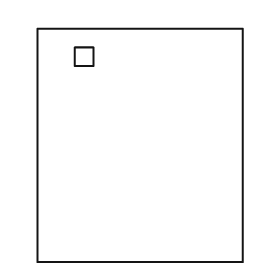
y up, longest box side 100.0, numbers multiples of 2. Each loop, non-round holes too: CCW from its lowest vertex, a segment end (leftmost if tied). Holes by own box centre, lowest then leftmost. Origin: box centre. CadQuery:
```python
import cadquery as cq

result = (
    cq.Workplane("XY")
    .moveTo(-44.0, -50.0)
    .lineTo(44.0, -50.0)
    .lineTo(44.0, 50.0)
    .lineTo(-44.0, 50.0)
    .close()
    .moveTo(-28.0, 34.0)
    .lineTo(-20.0, 34.0)
    .lineTo(-20.0, 42.0)
    .lineTo(-28.0, 42.0)
    .close()
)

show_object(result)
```